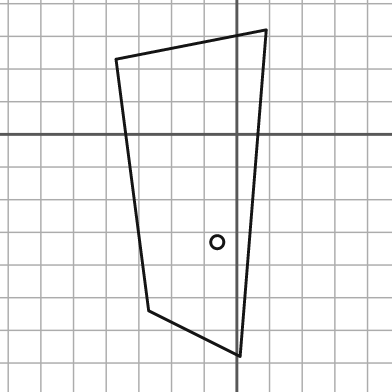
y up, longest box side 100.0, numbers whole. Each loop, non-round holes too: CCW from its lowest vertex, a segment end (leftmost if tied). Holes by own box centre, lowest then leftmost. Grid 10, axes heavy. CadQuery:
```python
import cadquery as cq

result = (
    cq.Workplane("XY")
    .moveTo(1.0, -68.0)
    .lineTo(9.0, 32.0)
    .lineTo(-37.0, 23.0)
    .lineTo(-27.0, -54.0)
    .close()
    .moveTo(-6.0, -33.0)
    .circle(2.0)
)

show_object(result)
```